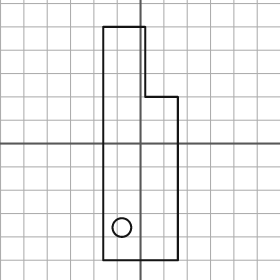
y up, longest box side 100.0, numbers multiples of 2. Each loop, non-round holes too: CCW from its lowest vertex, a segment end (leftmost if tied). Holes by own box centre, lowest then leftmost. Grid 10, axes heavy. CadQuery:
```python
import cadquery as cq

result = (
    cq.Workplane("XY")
    .moveTo(-16.0, -50.0)
    .lineTo(16.0, -50.0)
    .lineTo(16.0, 20.0)
    .lineTo(2.0, 20.0)
    .lineTo(2.0, 50.0)
    .lineTo(-16.0, 50.0)
    .close()
    .moveTo(-8.0, -36.0)
    .circle(4.0)
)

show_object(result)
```